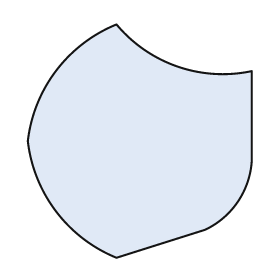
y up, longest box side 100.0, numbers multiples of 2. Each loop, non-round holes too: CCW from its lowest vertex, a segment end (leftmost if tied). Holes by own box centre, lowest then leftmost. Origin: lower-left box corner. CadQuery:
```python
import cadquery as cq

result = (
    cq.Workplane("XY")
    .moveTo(38.0, 0.0)
    .lineTo(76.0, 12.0)
    .threePointArc((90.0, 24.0), (96.0, 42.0))
    .lineTo(96.0, 80.0)
    .threePointArc((64.0, 82.0), (38.0, 100.0))
    .threePointArc((12.0, 80.0), (0.0, 50.0))
    .threePointArc((12.0, 20.0), (38.0, 0.0))
    .close()
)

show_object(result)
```